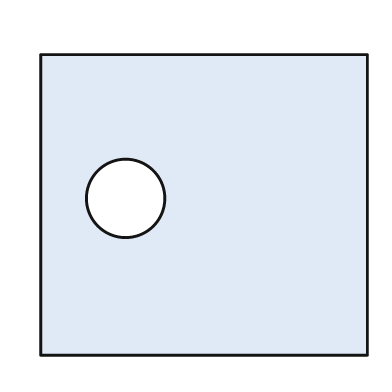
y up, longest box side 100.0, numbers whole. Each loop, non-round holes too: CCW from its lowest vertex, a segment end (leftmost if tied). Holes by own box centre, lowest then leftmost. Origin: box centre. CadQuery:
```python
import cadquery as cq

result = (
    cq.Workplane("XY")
    .moveTo(-50.0, -46.0)
    .lineTo(50.0, -46.0)
    .lineTo(50.0, 46.0)
    .lineTo(-50.0, 46.0)
    .close()
    .moveTo(-24.0, 2.0)
    .circle(12.0)
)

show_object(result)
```